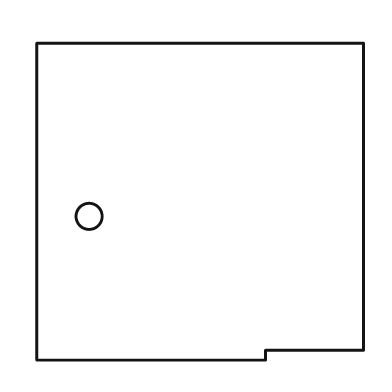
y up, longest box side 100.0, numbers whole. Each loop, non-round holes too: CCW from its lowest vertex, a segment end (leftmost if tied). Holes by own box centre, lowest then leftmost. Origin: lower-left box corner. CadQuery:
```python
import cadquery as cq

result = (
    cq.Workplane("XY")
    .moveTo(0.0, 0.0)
    .lineTo(70.0, 0.0)
    .lineTo(70.0, 3.0)
    .lineTo(100.0, 3.0)
    .lineTo(100.0, 97.0)
    .lineTo(0.0, 97.0)
    .close()
    .moveTo(16.0, 44.0)
    .circle(4.0)
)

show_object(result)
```